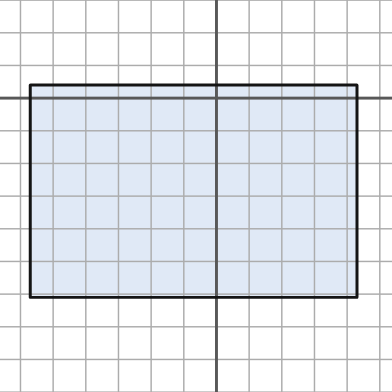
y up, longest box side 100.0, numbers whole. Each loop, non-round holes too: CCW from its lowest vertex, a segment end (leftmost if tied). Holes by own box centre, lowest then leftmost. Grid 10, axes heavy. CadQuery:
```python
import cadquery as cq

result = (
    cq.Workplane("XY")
    .moveTo(-57.0, -61.0)
    .lineTo(43.0, -61.0)
    .lineTo(43.0, 4.0)
    .lineTo(-57.0, 4.0)
    .close()
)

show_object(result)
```